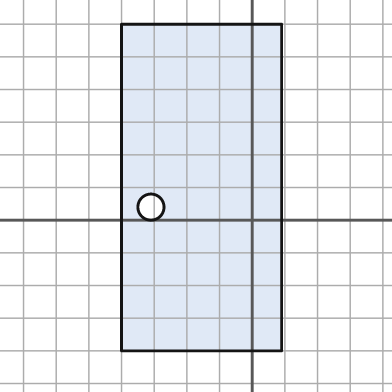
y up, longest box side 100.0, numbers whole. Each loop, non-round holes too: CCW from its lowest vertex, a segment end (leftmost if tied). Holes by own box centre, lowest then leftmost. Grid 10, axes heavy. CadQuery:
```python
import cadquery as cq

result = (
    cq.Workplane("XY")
    .moveTo(-40.0, -40.0)
    .lineTo(9.0, -40.0)
    .lineTo(9.0, 60.0)
    .lineTo(-40.0, 60.0)
    .close()
    .moveTo(-31.0, 4.0)
    .circle(4.0)
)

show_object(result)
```